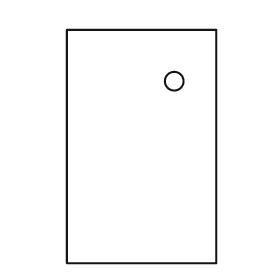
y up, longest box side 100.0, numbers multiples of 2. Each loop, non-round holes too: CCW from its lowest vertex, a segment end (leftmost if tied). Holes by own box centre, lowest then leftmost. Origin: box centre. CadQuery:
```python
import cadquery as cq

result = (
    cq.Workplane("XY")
    .moveTo(-32.0, -50.0)
    .lineTo(32.0, -50.0)
    .lineTo(32.0, 50.0)
    .lineTo(-32.0, 50.0)
    .close()
    .moveTo(14.0, 28.0)
    .circle(4.0)
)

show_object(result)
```